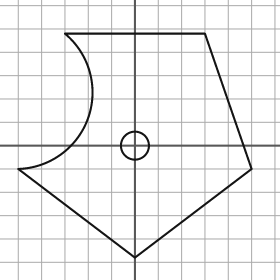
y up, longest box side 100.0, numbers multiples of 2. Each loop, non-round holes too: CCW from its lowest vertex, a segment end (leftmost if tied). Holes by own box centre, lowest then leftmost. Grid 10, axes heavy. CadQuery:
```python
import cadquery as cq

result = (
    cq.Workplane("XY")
    .moveTo(0.0, -48.0)
    .lineTo(50.0, -10.0)
    .lineTo(30.0, 48.0)
    .lineTo(-30.0, 48.0)
    .threePointArc((-20.0, 12.0), (-50.0, -10.0))
    .close()
    .moveTo(0.0, 0.0)
    .circle(6.0)
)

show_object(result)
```